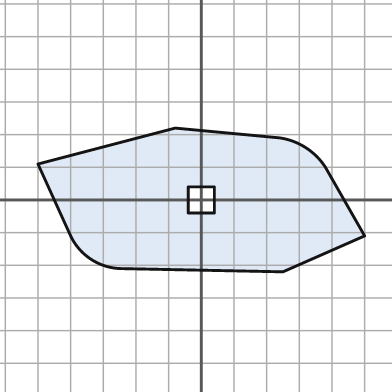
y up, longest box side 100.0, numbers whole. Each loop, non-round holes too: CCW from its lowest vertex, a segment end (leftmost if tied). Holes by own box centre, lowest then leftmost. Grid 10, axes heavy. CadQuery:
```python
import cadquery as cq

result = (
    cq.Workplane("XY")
    .moveTo(25.0, -22.0)
    .lineTo(50.0, -11.0)
    .lineTo(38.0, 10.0)
    .threePointArc((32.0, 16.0), (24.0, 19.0))
    .lineTo(-8.0, 22.0)
    .lineTo(-50.0, 11.0)
    .lineTo(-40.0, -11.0)
    .threePointArc((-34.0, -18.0), (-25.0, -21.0))
    .close()
    .moveTo(-4.0, -4.0)
    .lineTo(4.0, -4.0)
    .lineTo(4.0, 4.0)
    .lineTo(-4.0, 4.0)
    .close()
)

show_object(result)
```